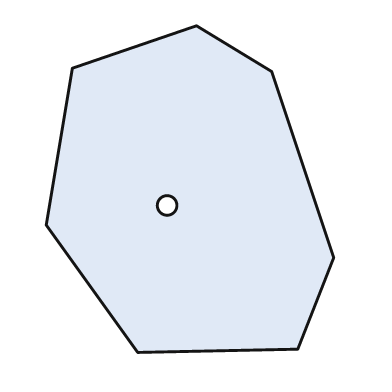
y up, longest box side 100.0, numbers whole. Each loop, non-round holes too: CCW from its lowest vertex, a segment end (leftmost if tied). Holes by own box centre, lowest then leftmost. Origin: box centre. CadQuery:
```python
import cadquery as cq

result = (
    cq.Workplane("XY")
    .moveTo(-16.0, -50.0)
    .lineTo(33.0, -49.0)
    .lineTo(44.0, -21.0)
    .lineTo(25.0, 36.0)
    .lineTo(2.0, 50.0)
    .lineTo(-36.0, 37.0)
    .lineTo(-44.0, -11.0)
    .close()
    .moveTo(-7.0, -5.0)
    .circle(3.0)
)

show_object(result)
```